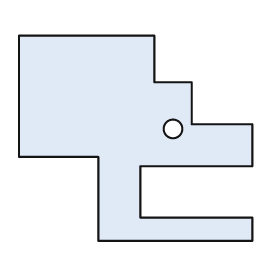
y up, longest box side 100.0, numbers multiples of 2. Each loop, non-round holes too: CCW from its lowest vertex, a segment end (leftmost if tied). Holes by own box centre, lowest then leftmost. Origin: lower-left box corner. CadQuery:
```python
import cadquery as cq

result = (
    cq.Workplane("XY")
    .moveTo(34.0, 0.0)
    .lineTo(100.0, 0.0)
    .lineTo(100.0, 10.0)
    .lineTo(52.0, 10.0)
    .lineTo(52.0, 32.0)
    .lineTo(100.0, 32.0)
    .lineTo(100.0, 50.0)
    .lineTo(74.0, 50.0)
    .lineTo(74.0, 68.0)
    .lineTo(58.0, 68.0)
    .lineTo(58.0, 88.0)
    .lineTo(0.0, 88.0)
    .lineTo(0.0, 36.0)
    .lineTo(34.0, 36.0)
    .close()
    .moveTo(66.0, 48.0)
    .circle(4.0)
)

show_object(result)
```